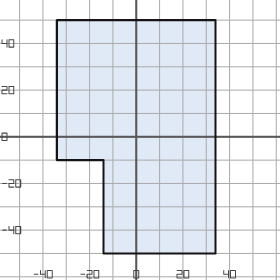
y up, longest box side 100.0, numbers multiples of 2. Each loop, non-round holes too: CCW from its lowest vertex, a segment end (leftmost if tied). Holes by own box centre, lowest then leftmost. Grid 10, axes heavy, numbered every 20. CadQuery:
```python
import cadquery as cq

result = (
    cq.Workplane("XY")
    .moveTo(-14.0, -50.0)
    .lineTo(34.0, -50.0)
    .lineTo(34.0, 50.0)
    .lineTo(-34.0, 50.0)
    .lineTo(-34.0, -10.0)
    .lineTo(-14.0, -10.0)
    .close()
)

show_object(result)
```